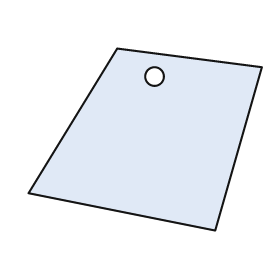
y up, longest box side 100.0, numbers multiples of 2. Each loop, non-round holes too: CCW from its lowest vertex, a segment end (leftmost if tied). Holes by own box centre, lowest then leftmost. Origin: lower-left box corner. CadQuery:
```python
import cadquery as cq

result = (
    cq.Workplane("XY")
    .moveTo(80.0, 0.0)
    .lineTo(100.0, 70.0)
    .lineTo(38.0, 78.0)
    .lineTo(0.0, 16.0)
    .close()
    .moveTo(54.0, 66.0)
    .circle(4.0)
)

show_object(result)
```